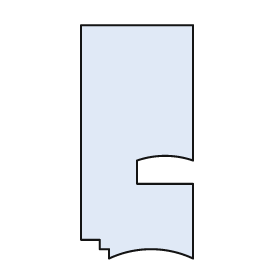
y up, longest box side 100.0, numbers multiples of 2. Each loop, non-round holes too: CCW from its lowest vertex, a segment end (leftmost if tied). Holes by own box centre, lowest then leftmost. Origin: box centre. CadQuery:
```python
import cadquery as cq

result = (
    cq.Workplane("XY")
    .moveTo(-12.0, -50.0)
    .threePointArc((6.0, -46.0), (24.0, -50.0))
    .lineTo(24.0, -18.0)
    .lineTo(0.0, -18.0)
    .lineTo(0.0, -8.0)
    .threePointArc((12.0, -6.0), (24.0, -8.0))
    .lineTo(24.0, 50.0)
    .lineTo(-24.0, 50.0)
    .lineTo(-24.0, -42.0)
    .lineTo(-16.0, -42.0)
    .lineTo(-16.0, -46.0)
    .lineTo(-12.0, -46.0)
    .close()
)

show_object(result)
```